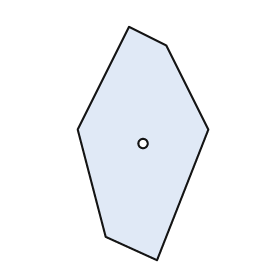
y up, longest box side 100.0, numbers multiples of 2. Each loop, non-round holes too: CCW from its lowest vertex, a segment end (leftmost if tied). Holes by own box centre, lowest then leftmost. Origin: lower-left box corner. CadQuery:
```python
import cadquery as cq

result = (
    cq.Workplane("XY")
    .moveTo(34.0, 0.0)
    .lineTo(56.0, 56.0)
    .lineTo(38.0, 92.0)
    .lineTo(22.0, 100.0)
    .lineTo(0.0, 56.0)
    .lineTo(12.0, 10.0)
    .close()
    .moveTo(28.0, 50.0)
    .circle(2.0)
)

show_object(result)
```